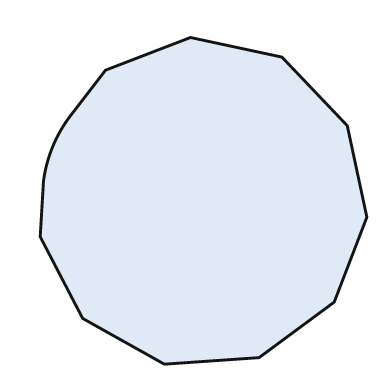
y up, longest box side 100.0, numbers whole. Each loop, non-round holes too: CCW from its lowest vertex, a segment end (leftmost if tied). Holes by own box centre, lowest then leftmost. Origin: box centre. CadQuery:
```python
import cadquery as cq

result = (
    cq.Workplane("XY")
    .moveTo(-12.0, -50.0)
    .lineTo(17.0, -48.0)
    .lineTo(40.0, -31.0)
    .lineTo(50.0, -5.0)
    .lineTo(44.0, 23.0)
    .lineTo(24.0, 44.0)
    .lineTo(-4.0, 50.0)
    .lineTo(-30.0, 40.0)
    .lineTo(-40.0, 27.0)
    .threePointArc((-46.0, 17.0), (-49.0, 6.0))
    .lineTo(-50.0, -11.0)
    .lineTo(-37.0, -36.0)
    .close()
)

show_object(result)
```